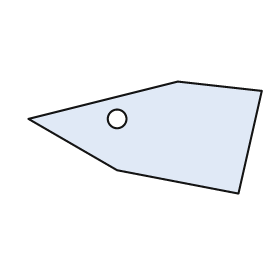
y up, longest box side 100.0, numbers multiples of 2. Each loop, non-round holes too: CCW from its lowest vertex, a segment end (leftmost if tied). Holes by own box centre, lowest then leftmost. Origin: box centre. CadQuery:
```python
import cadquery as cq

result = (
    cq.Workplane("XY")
    .moveTo(40.0, -24.0)
    .lineTo(50.0, 20.0)
    .lineTo(14.0, 24.0)
    .lineTo(-50.0, 8.0)
    .lineTo(-12.0, -14.0)
    .close()
    .moveTo(-12.0, 8.0)
    .circle(4.0)
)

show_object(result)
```